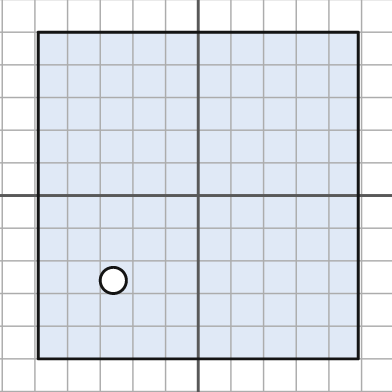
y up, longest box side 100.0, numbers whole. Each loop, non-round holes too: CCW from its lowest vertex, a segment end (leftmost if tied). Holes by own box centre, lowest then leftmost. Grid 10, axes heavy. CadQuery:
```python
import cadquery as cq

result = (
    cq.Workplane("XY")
    .moveTo(-49.0, -50.0)
    .lineTo(49.0, -50.0)
    .lineTo(49.0, 50.0)
    .lineTo(-49.0, 50.0)
    .close()
    .moveTo(-26.0, -26.0)
    .circle(4.0)
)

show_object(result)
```